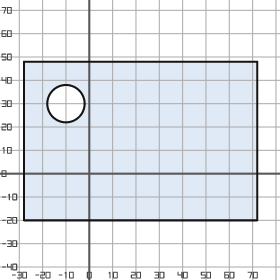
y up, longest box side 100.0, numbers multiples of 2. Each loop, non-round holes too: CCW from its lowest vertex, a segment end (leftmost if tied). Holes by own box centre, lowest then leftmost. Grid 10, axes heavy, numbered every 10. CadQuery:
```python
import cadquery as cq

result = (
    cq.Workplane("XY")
    .moveTo(-28.0, -20.0)
    .lineTo(72.0, -20.0)
    .lineTo(72.0, 48.0)
    .lineTo(-28.0, 48.0)
    .close()
    .moveTo(-10.0, 30.0)
    .circle(8.0)
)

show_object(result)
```